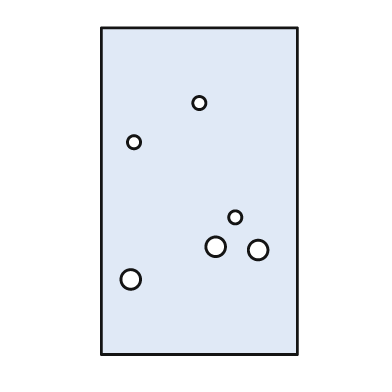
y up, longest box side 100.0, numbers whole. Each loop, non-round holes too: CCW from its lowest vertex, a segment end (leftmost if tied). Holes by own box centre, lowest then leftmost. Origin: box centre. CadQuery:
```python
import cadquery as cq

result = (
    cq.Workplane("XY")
    .moveTo(-30.0, -50.0)
    .lineTo(30.0, -50.0)
    .lineTo(30.0, 50.0)
    .lineTo(-30.0, 50.0)
    .close()
    .moveTo(-21.0, -27.0)
    .circle(3.0)
    .moveTo(18.0, -18.0)
    .circle(3.0)
    .moveTo(5.0, -17.0)
    .circle(3.0)
    .moveTo(11.0, -8.0)
    .circle(2.0)
    .moveTo(-20.0, 15.0)
    .circle(2.0)
    .moveTo(0.0, 27.0)
    .circle(2.0)
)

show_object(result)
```